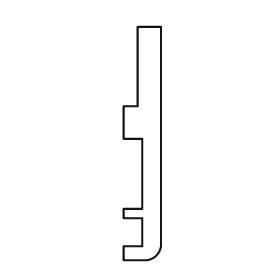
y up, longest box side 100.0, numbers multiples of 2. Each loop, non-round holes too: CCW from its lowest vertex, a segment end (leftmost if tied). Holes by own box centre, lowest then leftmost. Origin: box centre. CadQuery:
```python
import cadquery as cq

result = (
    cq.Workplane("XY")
    .moveTo(-8.0, -50.0)
    .lineTo(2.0, -50.0)
    .threePointArc((6.0, -48.0), (8.0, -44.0))
    .lineTo(8.0, 50.0)
    .lineTo(-2.0, 50.0)
    .lineTo(-2.0, 16.0)
    .lineTo(-8.0, 16.0)
    .lineTo(-8.0, 2.0)
    .lineTo(0.0, 2.0)
    .lineTo(0.0, -28.0)
    .lineTo(-8.0, -28.0)
    .lineTo(-8.0, -32.0)
    .lineTo(0.0, -32.0)
    .lineTo(0.0, -44.0)
    .lineTo(-8.0, -44.0)
    .close()
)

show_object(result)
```